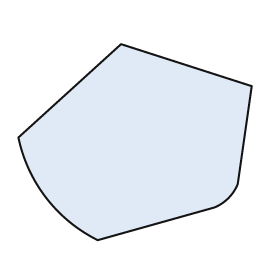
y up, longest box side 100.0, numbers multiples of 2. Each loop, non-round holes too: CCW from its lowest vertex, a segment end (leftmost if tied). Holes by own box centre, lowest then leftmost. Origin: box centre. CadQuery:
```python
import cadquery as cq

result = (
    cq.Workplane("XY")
    .moveTo(-16.0, -42.0)
    .lineTo(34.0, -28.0)
    .threePointArc((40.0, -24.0), (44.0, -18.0))
    .lineTo(50.0, 24.0)
    .lineTo(-6.0, 42.0)
    .lineTo(-50.0, 2.0)
    .threePointArc((-38.0, -24.0), (-16.0, -42.0))
    .close()
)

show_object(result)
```